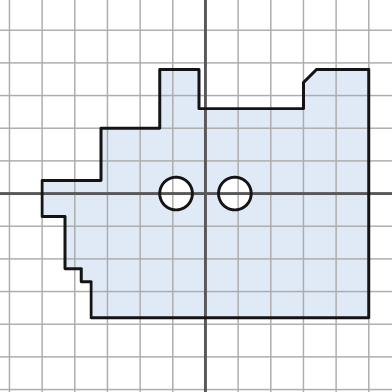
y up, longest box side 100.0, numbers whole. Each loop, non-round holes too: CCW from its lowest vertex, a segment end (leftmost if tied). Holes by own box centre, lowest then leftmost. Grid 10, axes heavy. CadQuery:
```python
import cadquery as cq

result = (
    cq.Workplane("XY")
    .moveTo(-35.0, -38.0)
    .lineTo(50.0, -38.0)
    .lineTo(50.0, 38.0)
    .lineTo(34.0, 38.0)
    .lineTo(30.0, 34.0)
    .lineTo(30.0, 26.0)
    .lineTo(-2.0, 26.0)
    .lineTo(-2.0, 38.0)
    .lineTo(-14.0, 38.0)
    .lineTo(-14.0, 20.0)
    .lineTo(-32.0, 20.0)
    .lineTo(-32.0, 4.0)
    .lineTo(-50.0, 4.0)
    .lineTo(-50.0, -7.0)
    .lineTo(-43.0, -7.0)
    .lineTo(-43.0, -23.0)
    .lineTo(-38.0, -23.0)
    .lineTo(-38.0, -27.0)
    .lineTo(-35.0, -27.0)
    .close()
    .moveTo(-9.0, 0.0)
    .circle(5.0)
    .moveTo(9.0, 0.0)
    .circle(5.0)
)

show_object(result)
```